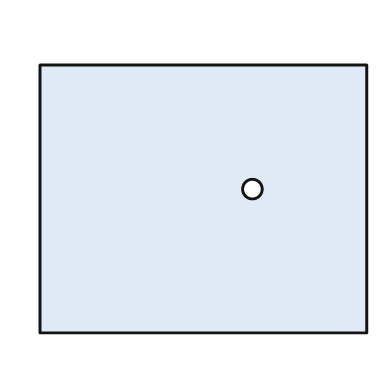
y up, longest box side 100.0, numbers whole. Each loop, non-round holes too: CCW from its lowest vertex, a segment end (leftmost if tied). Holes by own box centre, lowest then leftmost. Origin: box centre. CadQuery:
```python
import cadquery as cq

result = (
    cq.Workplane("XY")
    .moveTo(-50.0, -41.0)
    .lineTo(50.0, -41.0)
    .lineTo(50.0, 41.0)
    .lineTo(-50.0, 41.0)
    .close()
    .moveTo(15.0, 3.0)
    .circle(3.0)
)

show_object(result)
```